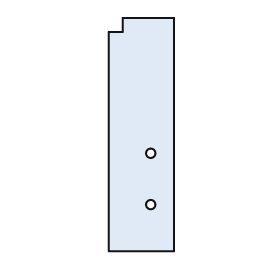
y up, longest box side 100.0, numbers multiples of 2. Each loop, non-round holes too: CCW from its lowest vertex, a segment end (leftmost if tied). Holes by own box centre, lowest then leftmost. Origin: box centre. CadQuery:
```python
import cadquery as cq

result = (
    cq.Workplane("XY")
    .moveTo(-14.0, -50.0)
    .lineTo(14.0, -50.0)
    .lineTo(14.0, 50.0)
    .lineTo(-8.0, 50.0)
    .lineTo(-8.0, 44.0)
    .lineTo(-14.0, 44.0)
    .close()
    .moveTo(4.0, -30.0)
    .circle(2.0)
    .moveTo(4.0, -8.0)
    .circle(2.0)
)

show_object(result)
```